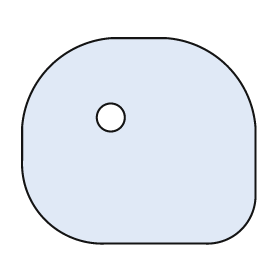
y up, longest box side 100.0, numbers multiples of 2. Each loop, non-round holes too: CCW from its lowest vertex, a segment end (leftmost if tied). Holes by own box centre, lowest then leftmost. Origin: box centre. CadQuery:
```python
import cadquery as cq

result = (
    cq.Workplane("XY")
    .moveTo(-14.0, -44.0)
    .lineTo(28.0, -44.0)
    .threePointArc((44.0, -38.0), (50.0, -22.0))
    .lineTo(50.0, 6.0)
    .threePointArc((38.0, 32.0), (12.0, 44.0))
    .lineTo(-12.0, 44.0)
    .threePointArc((-38.0, 32.0), (-50.0, 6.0))
    .lineTo(-50.0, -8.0)
    .threePointArc((-40.0, -34.0), (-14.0, -44.0))
    .close()
    .moveTo(-12.0, 10.0)
    .circle(6.0)
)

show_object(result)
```